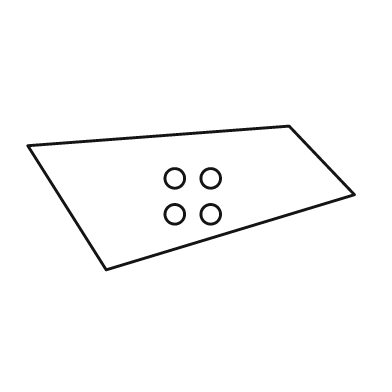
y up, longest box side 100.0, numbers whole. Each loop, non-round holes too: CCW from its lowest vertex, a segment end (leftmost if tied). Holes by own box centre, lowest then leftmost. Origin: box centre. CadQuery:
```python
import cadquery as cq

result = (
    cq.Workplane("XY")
    .moveTo(-26.0, -22.0)
    .lineTo(50.0, 1.0)
    .lineTo(30.0, 22.0)
    .lineTo(-50.0, 16.0)
    .close()
    .moveTo(-5.0, -5.0)
    .circle(3.0)
    .moveTo(6.0, -5.0)
    .circle(3.0)
    .moveTo(-5.0, 6.0)
    .circle(3.0)
    .moveTo(6.0, 6.0)
    .circle(3.0)
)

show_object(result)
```